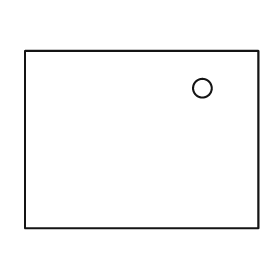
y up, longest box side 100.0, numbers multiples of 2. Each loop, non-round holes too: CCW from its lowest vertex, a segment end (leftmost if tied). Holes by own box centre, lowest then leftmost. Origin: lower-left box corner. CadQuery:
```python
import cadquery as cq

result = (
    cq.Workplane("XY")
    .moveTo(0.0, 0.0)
    .lineTo(100.0, 0.0)
    .lineTo(100.0, 76.0)
    .lineTo(0.0, 76.0)
    .close()
    .moveTo(76.0, 60.0)
    .circle(4.0)
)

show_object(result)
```